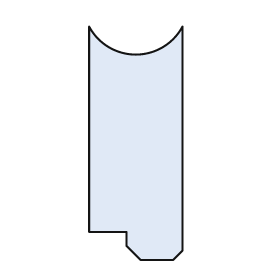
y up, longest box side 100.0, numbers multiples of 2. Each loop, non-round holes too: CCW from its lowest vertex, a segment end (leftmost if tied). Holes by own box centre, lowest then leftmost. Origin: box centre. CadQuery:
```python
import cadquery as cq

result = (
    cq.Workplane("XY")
    .moveTo(2.0, -50.0)
    .lineTo(16.0, -50.0)
    .lineTo(20.0, -46.0)
    .lineTo(20.0, 50.0)
    .threePointArc((0.0, 38.0), (-20.0, 50.0))
    .lineTo(-20.0, -38.0)
    .lineTo(-4.0, -38.0)
    .lineTo(-4.0, -44.0)
    .close()
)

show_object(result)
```